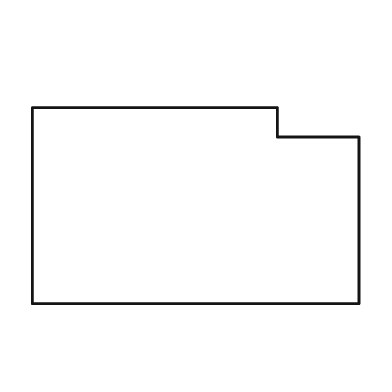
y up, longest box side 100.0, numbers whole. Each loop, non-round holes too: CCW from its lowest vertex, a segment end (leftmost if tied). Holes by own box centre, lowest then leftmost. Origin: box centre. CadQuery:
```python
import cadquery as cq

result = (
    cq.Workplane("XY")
    .moveTo(-50.0, -30.0)
    .lineTo(50.0, -30.0)
    .lineTo(50.0, 21.0)
    .lineTo(25.0, 21.0)
    .lineTo(25.0, 30.0)
    .lineTo(-50.0, 30.0)
    .close()
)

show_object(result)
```